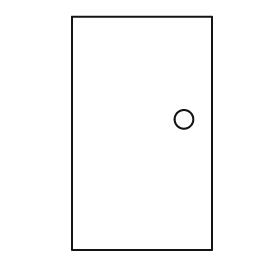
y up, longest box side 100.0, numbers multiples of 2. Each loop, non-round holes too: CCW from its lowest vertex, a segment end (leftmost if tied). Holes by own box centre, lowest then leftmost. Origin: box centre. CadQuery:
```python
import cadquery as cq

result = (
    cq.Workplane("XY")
    .moveTo(-30.0, -50.0)
    .lineTo(30.0, -50.0)
    .lineTo(30.0, 50.0)
    .lineTo(-30.0, 50.0)
    .close()
    .moveTo(18.0, 6.0)
    .circle(4.0)
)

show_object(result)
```